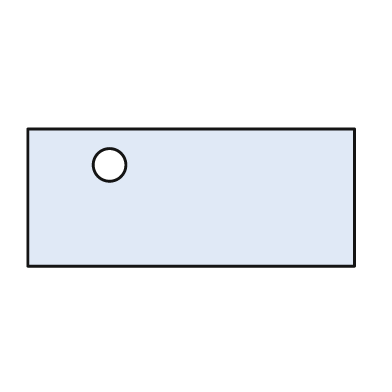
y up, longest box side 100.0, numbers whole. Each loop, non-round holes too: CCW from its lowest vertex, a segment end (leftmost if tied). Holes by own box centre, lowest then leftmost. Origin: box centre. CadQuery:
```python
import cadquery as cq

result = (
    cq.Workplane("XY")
    .moveTo(-50.0, -21.0)
    .lineTo(50.0, -21.0)
    .lineTo(50.0, 21.0)
    .lineTo(-50.0, 21.0)
    .close()
    .moveTo(-25.0, 10.0)
    .circle(5.0)
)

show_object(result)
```